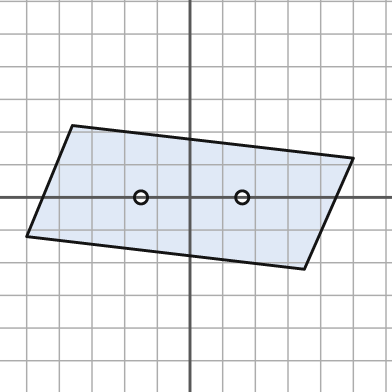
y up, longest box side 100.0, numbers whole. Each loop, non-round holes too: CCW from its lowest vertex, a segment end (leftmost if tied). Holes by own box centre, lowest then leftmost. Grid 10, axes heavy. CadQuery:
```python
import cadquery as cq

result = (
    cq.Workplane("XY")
    .moveTo(35.0, -22.0)
    .lineTo(50.0, 12.0)
    .lineTo(-36.0, 22.0)
    .lineTo(-50.0, -12.0)
    .close()
    .moveTo(-15.0, 0.0)
    .circle(2.0)
    .moveTo(16.0, 0.0)
    .circle(2.0)
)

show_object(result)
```